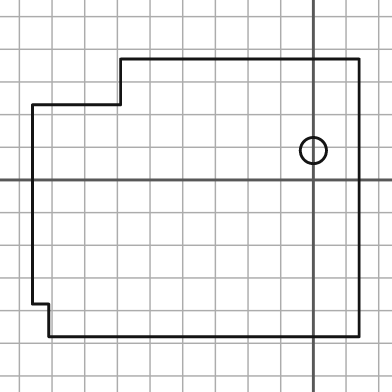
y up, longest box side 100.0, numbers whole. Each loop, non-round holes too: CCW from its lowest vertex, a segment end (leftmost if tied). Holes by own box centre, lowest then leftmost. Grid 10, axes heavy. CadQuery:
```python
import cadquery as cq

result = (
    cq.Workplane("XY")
    .moveTo(-81.0, -48.0)
    .lineTo(14.0, -48.0)
    .lineTo(14.0, 37.0)
    .lineTo(-59.0, 37.0)
    .lineTo(-59.0, 23.0)
    .lineTo(-86.0, 23.0)
    .lineTo(-86.0, -38.0)
    .lineTo(-81.0, -38.0)
    .close()
    .moveTo(0.0, 9.0)
    .circle(4.0)
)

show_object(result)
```